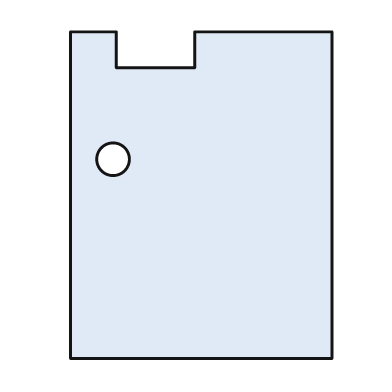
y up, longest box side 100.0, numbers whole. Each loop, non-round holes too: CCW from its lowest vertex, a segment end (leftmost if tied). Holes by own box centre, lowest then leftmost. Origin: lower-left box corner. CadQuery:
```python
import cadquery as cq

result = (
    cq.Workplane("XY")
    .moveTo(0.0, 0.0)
    .lineTo(80.0, 0.0)
    .lineTo(80.0, 100.0)
    .lineTo(38.0, 100.0)
    .lineTo(38.0, 89.0)
    .lineTo(14.0, 89.0)
    .lineTo(14.0, 100.0)
    .lineTo(0.0, 100.0)
    .close()
    .moveTo(13.0, 61.0)
    .circle(5.0)
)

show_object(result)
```